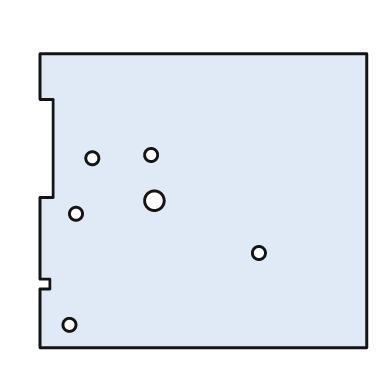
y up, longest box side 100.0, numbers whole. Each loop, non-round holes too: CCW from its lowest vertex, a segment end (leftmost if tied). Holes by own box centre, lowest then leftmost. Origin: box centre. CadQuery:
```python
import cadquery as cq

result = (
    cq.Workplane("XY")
    .moveTo(-50.0, -45.0)
    .lineTo(50.0, -45.0)
    .lineTo(50.0, 45.0)
    .lineTo(-50.0, 45.0)
    .lineTo(-50.0, 31.0)
    .lineTo(-46.0, 31.0)
    .lineTo(-46.0, 1.0)
    .lineTo(-50.0, 1.0)
    .lineTo(-50.0, -24.0)
    .lineTo(-47.0, -24.0)
    .lineTo(-47.0, -27.0)
    .lineTo(-50.0, -27.0)
    .close()
    .moveTo(-41.0, -38.0)
    .circle(2.0)
    .moveTo(17.0, -16.0)
    .circle(2.0)
    .moveTo(-39.0, -4.0)
    .circle(2.0)
    .moveTo(-15.0, 0.0)
    .circle(3.0)
    .moveTo(-34.0, 13.0)
    .circle(2.0)
    .moveTo(-16.0, 14.0)
    .circle(2.0)
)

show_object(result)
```